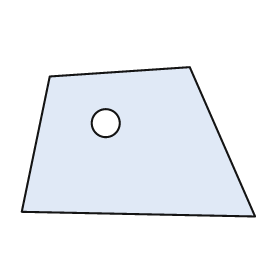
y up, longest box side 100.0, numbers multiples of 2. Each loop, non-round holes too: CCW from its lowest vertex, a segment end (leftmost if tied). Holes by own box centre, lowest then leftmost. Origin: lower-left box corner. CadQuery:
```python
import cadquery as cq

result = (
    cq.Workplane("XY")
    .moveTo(100.0, 0.0)
    .lineTo(72.0, 64.0)
    .lineTo(12.0, 60.0)
    .lineTo(0.0, 2.0)
    .close()
    .moveTo(36.0, 40.0)
    .circle(6.0)
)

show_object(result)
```